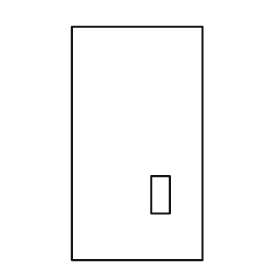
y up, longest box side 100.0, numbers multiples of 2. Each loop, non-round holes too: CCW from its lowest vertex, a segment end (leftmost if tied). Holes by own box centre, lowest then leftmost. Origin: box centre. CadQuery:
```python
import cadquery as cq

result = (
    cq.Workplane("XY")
    .moveTo(-28.0, -50.0)
    .lineTo(28.0, -50.0)
    .lineTo(28.0, 50.0)
    .lineTo(-28.0, 50.0)
    .close()
    .moveTo(6.0, -30.0)
    .lineTo(14.0, -30.0)
    .lineTo(14.0, -14.0)
    .lineTo(6.0, -14.0)
    .close()
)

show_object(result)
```